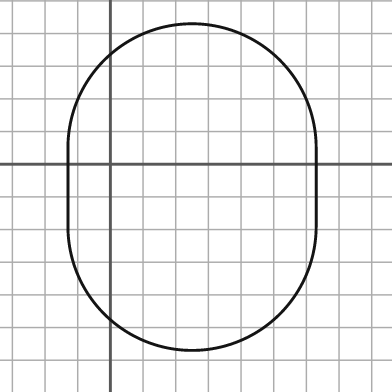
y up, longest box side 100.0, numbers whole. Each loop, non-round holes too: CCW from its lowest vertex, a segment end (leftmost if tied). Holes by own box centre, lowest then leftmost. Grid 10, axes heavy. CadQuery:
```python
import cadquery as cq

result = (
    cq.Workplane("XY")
    .moveTo(-13.0, -19.0)
    .threePointArc((25.0, -57.0), (63.0, -19.0))
    .lineTo(63.0, 5.0)
    .threePointArc((25.0, 43.0), (-13.0, 5.0))
    .close()
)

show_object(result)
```